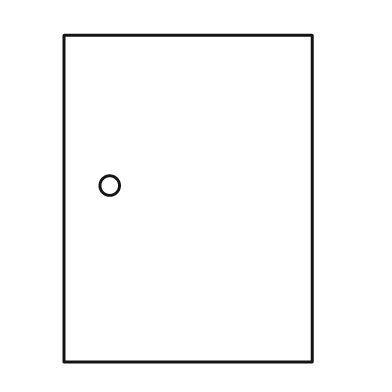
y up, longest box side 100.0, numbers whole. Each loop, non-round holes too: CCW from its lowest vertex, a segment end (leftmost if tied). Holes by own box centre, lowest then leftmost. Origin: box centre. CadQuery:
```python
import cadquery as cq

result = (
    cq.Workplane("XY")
    .moveTo(-38.0, -50.0)
    .lineTo(38.0, -50.0)
    .lineTo(38.0, 50.0)
    .lineTo(-38.0, 50.0)
    .close()
    .moveTo(-24.0, 4.0)
    .circle(3.0)
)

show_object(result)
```